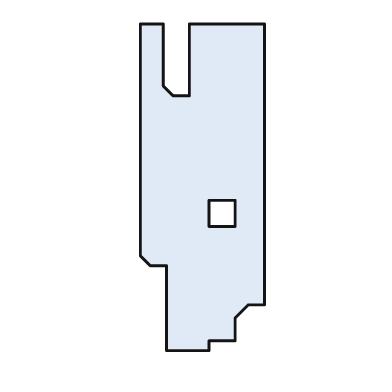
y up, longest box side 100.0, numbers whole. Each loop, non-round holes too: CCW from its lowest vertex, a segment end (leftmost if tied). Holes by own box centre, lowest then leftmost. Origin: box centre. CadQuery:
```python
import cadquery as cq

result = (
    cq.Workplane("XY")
    .moveTo(-11.0, -50.0)
    .lineTo(2.0, -50.0)
    .lineTo(2.0, -47.0)
    .lineTo(10.0, -47.0)
    .lineTo(10.0, -40.0)
    .lineTo(14.0, -36.0)
    .lineTo(19.0, -36.0)
    .lineTo(19.0, 50.0)
    .lineTo(-4.0, 50.0)
    .lineTo(-4.0, 28.0)
    .lineTo(-9.0, 28.0)
    .lineTo(-12.0, 31.0)
    .lineTo(-12.0, 50.0)
    .lineTo(-19.0, 50.0)
    .lineTo(-19.0, -21.0)
    .lineTo(-16.0, -24.0)
    .lineTo(-11.0, -24.0)
    .close()
    .moveTo(2.0, -12.0)
    .lineTo(10.0, -12.0)
    .lineTo(10.0, -4.0)
    .lineTo(2.0, -4.0)
    .close()
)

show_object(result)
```